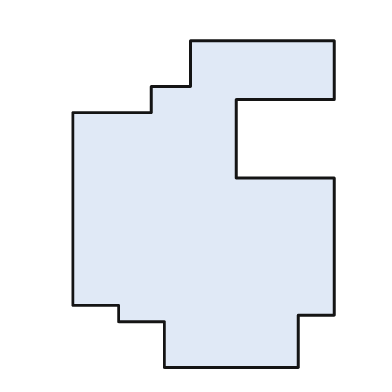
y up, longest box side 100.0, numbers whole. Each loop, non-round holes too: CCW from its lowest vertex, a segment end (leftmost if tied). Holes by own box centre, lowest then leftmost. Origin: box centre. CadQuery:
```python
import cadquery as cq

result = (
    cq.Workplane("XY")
    .moveTo(-12.0, -50.0)
    .lineTo(29.0, -50.0)
    .lineTo(29.0, -34.0)
    .lineTo(40.0, -34.0)
    .lineTo(40.0, 8.0)
    .lineTo(10.0, 8.0)
    .lineTo(10.0, 32.0)
    .lineTo(40.0, 32.0)
    .lineTo(40.0, 50.0)
    .lineTo(-4.0, 50.0)
    .lineTo(-4.0, 36.0)
    .lineTo(-16.0, 36.0)
    .lineTo(-16.0, 28.0)
    .lineTo(-40.0, 28.0)
    .lineTo(-40.0, -31.0)
    .lineTo(-26.0, -31.0)
    .lineTo(-26.0, -36.0)
    .lineTo(-12.0, -36.0)
    .close()
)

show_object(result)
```